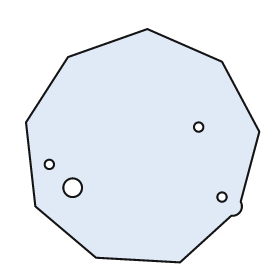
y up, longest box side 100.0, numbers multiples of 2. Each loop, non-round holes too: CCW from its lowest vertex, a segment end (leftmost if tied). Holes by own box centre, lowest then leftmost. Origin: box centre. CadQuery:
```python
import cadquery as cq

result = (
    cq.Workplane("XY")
    .moveTo(16.0, -50.0)
    .lineTo(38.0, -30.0)
    .threePointArc((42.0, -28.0), (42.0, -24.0))
    .lineTo(50.0, 6.0)
    .lineTo(34.0, 36.0)
    .lineTo(2.0, 50.0)
    .lineTo(-32.0, 38.0)
    .lineTo(-50.0, 10.0)
    .lineTo(-46.0, -26.0)
    .lineTo(-20.0, -48.0)
    .close()
    .moveTo(34.0, -22.0)
    .circle(2.0)
    .moveTo(-30.0, -18.0)
    .circle(4.0)
    .moveTo(-40.0, -8.0)
    .circle(2.0)
    .moveTo(24.0, 8.0)
    .circle(2.0)
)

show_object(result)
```